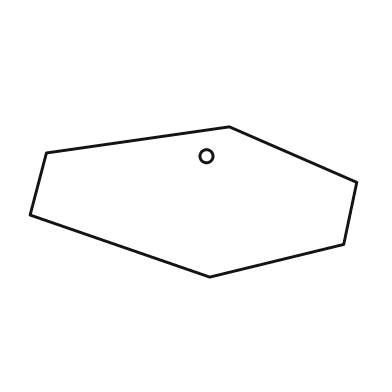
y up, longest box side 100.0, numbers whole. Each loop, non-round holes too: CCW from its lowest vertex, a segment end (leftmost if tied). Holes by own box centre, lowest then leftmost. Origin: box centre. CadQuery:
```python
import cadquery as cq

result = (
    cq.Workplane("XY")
    .moveTo(5.0, -23.0)
    .lineTo(46.0, -13.0)
    .lineTo(50.0, 6.0)
    .lineTo(11.0, 23.0)
    .lineTo(-45.0, 15.0)
    .lineTo(-50.0, -4.0)
    .close()
    .moveTo(4.0, 14.0)
    .circle(2.0)
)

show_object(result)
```